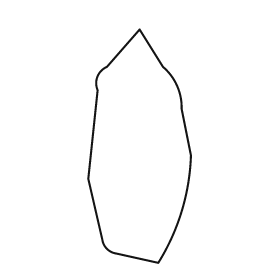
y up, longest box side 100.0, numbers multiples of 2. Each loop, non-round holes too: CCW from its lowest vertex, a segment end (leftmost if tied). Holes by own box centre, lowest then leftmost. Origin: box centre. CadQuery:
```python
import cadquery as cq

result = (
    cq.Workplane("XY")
    .moveTo(8.0, -50.0)
    .threePointArc((18.0, -28.0), (22.0, -4.0))
    .lineTo(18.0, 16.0)
    .threePointArc((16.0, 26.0), (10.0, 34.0))
    .lineTo(0.0, 50.0)
    .lineTo(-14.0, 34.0)
    .threePointArc((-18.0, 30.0), (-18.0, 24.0))
    .lineTo(-22.0, -14.0)
    .lineTo(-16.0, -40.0)
    .threePointArc((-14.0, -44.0), (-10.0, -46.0))
    .close()
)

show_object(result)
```